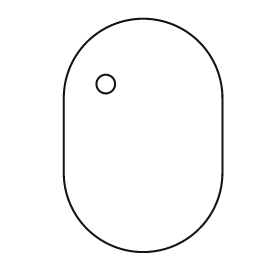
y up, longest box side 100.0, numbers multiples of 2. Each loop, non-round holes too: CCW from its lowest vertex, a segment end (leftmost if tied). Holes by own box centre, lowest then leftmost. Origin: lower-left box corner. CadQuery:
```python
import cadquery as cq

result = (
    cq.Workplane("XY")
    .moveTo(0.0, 34.0)
    .threePointArc((34.0, 0.0), (68.0, 34.0))
    .lineTo(68.0, 66.0)
    .threePointArc((34.0, 100.0), (0.0, 66.0))
    .close()
    .moveTo(18.0, 72.0)
    .circle(4.0)
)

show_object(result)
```